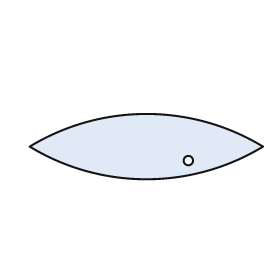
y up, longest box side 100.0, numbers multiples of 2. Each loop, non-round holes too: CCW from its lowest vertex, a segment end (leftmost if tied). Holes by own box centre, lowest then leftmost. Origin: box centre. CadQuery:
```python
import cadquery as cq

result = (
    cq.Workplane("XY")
    .moveTo(-50.0, 0.0)
    .threePointArc((0.0, -14.0), (50.0, 0.0))
    .threePointArc((0.0, 14.0), (-50.0, 0.0))
    .close()
    .moveTo(18.0, -6.0)
    .circle(2.0)
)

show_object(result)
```